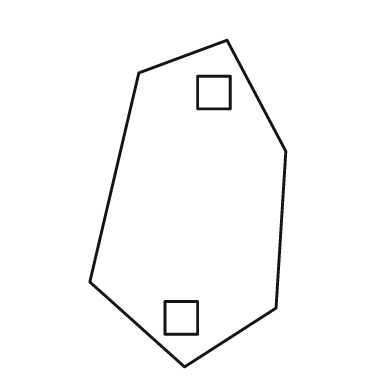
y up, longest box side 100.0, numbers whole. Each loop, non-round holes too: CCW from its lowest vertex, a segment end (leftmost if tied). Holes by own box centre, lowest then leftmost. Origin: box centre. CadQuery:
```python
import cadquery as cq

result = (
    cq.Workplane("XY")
    .moveTo(-1.0, -50.0)
    .lineTo(27.0, -32.0)
    .lineTo(30.0, 16.0)
    .lineTo(12.0, 50.0)
    .lineTo(-15.0, 40.0)
    .lineTo(-30.0, -24.0)
    .close()
    .moveTo(-7.0, -40.0)
    .lineTo(3.0, -40.0)
    .lineTo(3.0, -30.0)
    .lineTo(-7.0, -30.0)
    .close()
    .moveTo(3.0, 29.0)
    .lineTo(13.0, 29.0)
    .lineTo(13.0, 39.0)
    .lineTo(3.0, 39.0)
    .close()
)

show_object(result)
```